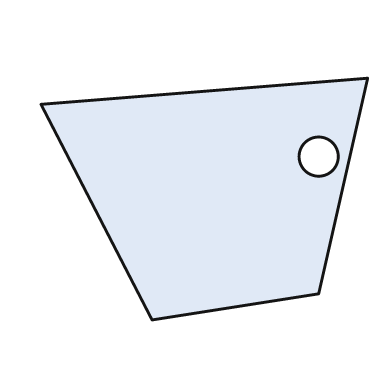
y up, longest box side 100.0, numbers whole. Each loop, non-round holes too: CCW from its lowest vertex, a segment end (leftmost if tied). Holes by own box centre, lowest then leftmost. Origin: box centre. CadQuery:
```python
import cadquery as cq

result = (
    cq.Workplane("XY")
    .moveTo(-16.0, -37.0)
    .lineTo(35.0, -29.0)
    .lineTo(50.0, 37.0)
    .lineTo(-50.0, 29.0)
    .close()
    .moveTo(35.0, 13.0)
    .circle(6.0)
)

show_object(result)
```